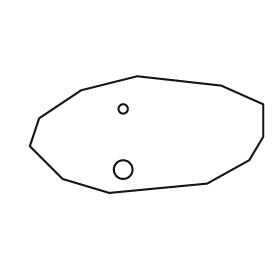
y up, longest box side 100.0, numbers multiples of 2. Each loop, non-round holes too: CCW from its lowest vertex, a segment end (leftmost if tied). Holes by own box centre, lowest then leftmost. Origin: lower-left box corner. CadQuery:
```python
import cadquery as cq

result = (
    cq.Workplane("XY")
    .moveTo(34.0, 0.0)
    .lineTo(76.0, 4.0)
    .lineTo(94.0, 14.0)
    .lineTo(100.0, 24.0)
    .lineTo(100.0, 38.0)
    .lineTo(82.0, 46.0)
    .lineTo(46.0, 50.0)
    .lineTo(22.0, 44.0)
    .lineTo(4.0, 32.0)
    .lineTo(0.0, 20.0)
    .lineTo(14.0, 6.0)
    .close()
    .moveTo(40.0, 10.0)
    .circle(4.0)
    .moveTo(40.0, 36.0)
    .circle(2.0)
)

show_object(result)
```